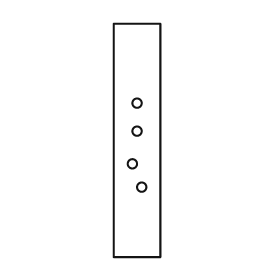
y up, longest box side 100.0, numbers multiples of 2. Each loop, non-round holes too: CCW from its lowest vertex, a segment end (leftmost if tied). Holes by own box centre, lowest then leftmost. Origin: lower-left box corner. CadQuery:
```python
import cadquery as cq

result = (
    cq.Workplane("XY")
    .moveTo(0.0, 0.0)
    .lineTo(20.0, 0.0)
    .lineTo(20.0, 100.0)
    .lineTo(0.0, 100.0)
    .close()
    .moveTo(12.0, 30.0)
    .circle(2.0)
    .moveTo(8.0, 40.0)
    .circle(2.0)
    .moveTo(10.0, 54.0)
    .circle(2.0)
    .moveTo(10.0, 66.0)
    .circle(2.0)
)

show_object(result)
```